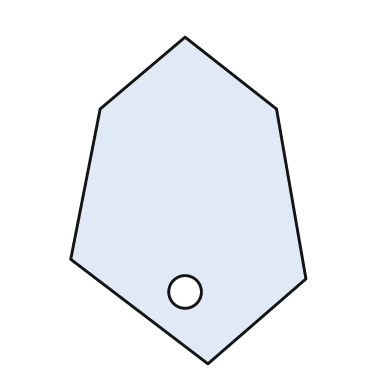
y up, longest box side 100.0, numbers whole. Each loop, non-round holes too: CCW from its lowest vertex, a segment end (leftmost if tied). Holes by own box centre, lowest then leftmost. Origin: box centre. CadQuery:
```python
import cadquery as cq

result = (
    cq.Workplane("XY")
    .moveTo(6.0, -50.0)
    .lineTo(36.0, -24.0)
    .lineTo(27.0, 28.0)
    .lineTo(-1.0, 50.0)
    .lineTo(-27.0, 28.0)
    .lineTo(-36.0, -18.0)
    .close()
    .moveTo(-1.0, -28.0)
    .circle(5.0)
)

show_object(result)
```